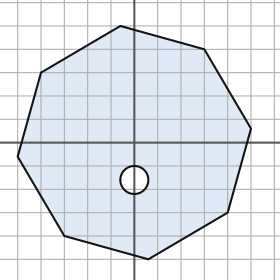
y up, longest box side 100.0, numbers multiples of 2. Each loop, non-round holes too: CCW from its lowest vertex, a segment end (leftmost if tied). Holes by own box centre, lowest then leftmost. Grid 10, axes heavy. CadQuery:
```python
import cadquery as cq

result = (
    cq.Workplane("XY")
    .moveTo(6.0, -50.0)
    .lineTo(40.0, -30.0)
    .lineTo(50.0, 6.0)
    .lineTo(30.0, 40.0)
    .lineTo(-6.0, 50.0)
    .lineTo(-40.0, 30.0)
    .lineTo(-50.0, -6.0)
    .lineTo(-30.0, -40.0)
    .close()
    .moveTo(0.0, -16.0)
    .circle(6.0)
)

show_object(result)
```